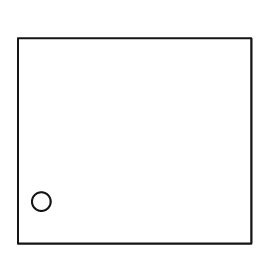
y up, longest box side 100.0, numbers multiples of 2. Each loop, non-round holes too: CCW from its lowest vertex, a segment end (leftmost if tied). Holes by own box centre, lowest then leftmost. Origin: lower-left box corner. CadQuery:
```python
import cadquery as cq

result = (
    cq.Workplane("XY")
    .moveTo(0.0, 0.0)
    .lineTo(100.0, 0.0)
    .lineTo(100.0, 88.0)
    .lineTo(0.0, 88.0)
    .close()
    .moveTo(10.0, 18.0)
    .circle(4.0)
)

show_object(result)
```